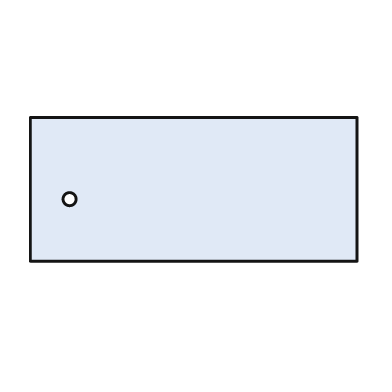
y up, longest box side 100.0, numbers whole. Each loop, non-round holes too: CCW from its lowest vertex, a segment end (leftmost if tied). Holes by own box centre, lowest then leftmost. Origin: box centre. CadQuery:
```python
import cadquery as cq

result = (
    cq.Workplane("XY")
    .moveTo(-50.0, -22.0)
    .lineTo(50.0, -22.0)
    .lineTo(50.0, 22.0)
    .lineTo(-50.0, 22.0)
    .close()
    .moveTo(-38.0, -3.0)
    .circle(2.0)
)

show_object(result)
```